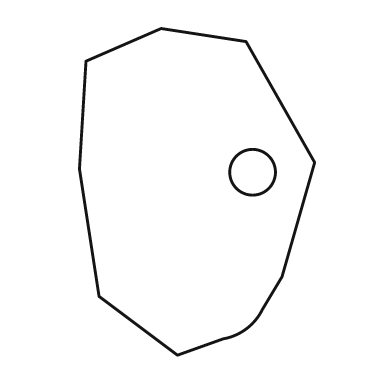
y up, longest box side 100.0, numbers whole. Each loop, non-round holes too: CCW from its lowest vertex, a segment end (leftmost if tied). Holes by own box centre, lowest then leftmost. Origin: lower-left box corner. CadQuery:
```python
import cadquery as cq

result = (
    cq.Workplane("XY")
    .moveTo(30.0, 0.0)
    .lineTo(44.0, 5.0)
    .threePointArc((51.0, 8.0), (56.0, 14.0))
    .lineTo(62.0, 24.0)
    .lineTo(72.0, 59.0)
    .lineTo(51.0, 96.0)
    .lineTo(25.0, 100.0)
    .lineTo(2.0, 90.0)
    .lineTo(0.0, 57.0)
    .lineTo(6.0, 18.0)
    .close()
    .moveTo(53.0, 56.0)
    .circle(7.0)
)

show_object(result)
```